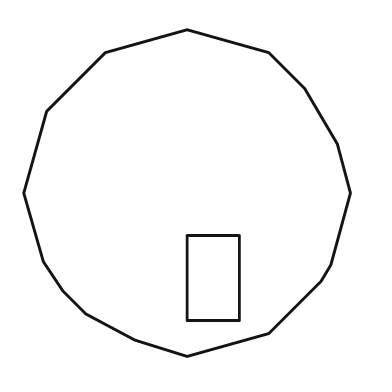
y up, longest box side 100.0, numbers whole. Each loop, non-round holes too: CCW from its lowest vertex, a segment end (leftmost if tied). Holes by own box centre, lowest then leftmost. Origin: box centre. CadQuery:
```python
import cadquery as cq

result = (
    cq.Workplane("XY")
    .moveTo(0.0, -50.0)
    .lineTo(25.0, -43.0)
    .lineTo(41.0, -27.0)
    .lineTo(44.0, -22.0)
    .lineTo(50.0, 0.0)
    .lineTo(46.0, 15.0)
    .lineTo(36.0, 32.0)
    .lineTo(25.0, 43.0)
    .lineTo(0.0, 50.0)
    .lineTo(-25.0, 43.0)
    .lineTo(-43.0, 25.0)
    .lineTo(-50.0, 0.0)
    .lineTo(-44.0, -21.0)
    .lineTo(-38.0, -30.0)
    .lineTo(-31.0, -37.0)
    .lineTo(-16.0, -45.0)
    .close()
    .moveTo(0.0, -39.0)
    .lineTo(16.0, -39.0)
    .lineTo(16.0, -13.0)
    .lineTo(0.0, -13.0)
    .close()
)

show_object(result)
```